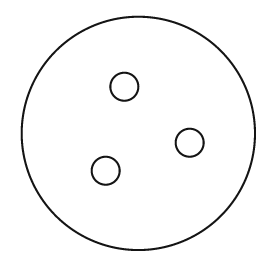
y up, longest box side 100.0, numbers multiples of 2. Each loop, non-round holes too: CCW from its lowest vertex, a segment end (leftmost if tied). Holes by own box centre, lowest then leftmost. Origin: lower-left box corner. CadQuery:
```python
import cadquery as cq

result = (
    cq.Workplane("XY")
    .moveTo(50.0, 50.0)
    .circle(50.0)
    .moveTo(36.0, 34.0)
    .circle(6.0)
    .moveTo(72.0, 46.0)
    .circle(6.0)
    .moveTo(44.0, 70.0)
    .circle(6.0)
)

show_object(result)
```